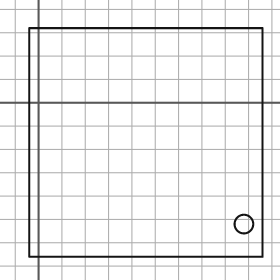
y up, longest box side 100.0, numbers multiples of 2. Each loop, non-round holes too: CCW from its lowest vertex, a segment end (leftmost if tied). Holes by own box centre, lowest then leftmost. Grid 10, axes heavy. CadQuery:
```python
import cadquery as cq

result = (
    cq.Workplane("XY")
    .moveTo(-4.0, -66.0)
    .lineTo(96.0, -66.0)
    .lineTo(96.0, 32.0)
    .lineTo(-4.0, 32.0)
    .close()
    .moveTo(88.0, -52.0)
    .circle(4.0)
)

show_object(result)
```